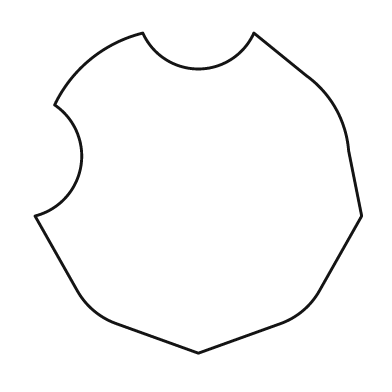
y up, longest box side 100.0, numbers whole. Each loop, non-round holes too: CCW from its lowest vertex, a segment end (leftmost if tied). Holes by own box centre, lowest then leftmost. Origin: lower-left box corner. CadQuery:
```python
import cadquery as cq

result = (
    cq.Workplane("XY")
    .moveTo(50.0, 0.0)
    .lineTo(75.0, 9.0)
    .threePointArc((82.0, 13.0), (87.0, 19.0))
    .lineTo(100.0, 42.0)
    .lineTo(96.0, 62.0)
    .threePointArc((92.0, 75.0), (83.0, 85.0))
    .lineTo(67.0, 98.0)
    .threePointArc((50.0, 87.0), (33.0, 98.0))
    .threePointArc((17.0, 90.0), (6.0, 76.0))
    .threePointArc((14.0, 57.0), (0.0, 42.0))
    .lineTo(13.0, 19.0)
    .threePointArc((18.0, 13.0), (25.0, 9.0))
    .close()
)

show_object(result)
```